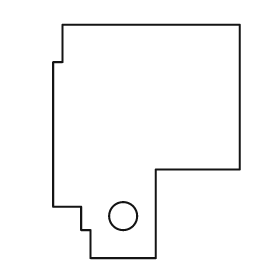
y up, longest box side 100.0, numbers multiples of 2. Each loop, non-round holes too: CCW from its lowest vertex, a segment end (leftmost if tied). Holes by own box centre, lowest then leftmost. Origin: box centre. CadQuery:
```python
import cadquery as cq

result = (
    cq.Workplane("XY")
    .moveTo(-24.0, -50.0)
    .lineTo(4.0, -50.0)
    .lineTo(4.0, -12.0)
    .lineTo(40.0, -12.0)
    .lineTo(40.0, 50.0)
    .lineTo(-36.0, 50.0)
    .lineTo(-36.0, 34.0)
    .lineTo(-40.0, 34.0)
    .lineTo(-40.0, -28.0)
    .lineTo(-28.0, -28.0)
    .lineTo(-28.0, -38.0)
    .lineTo(-24.0, -38.0)
    .close()
    .moveTo(-10.0, -32.0)
    .circle(6.0)
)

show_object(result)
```